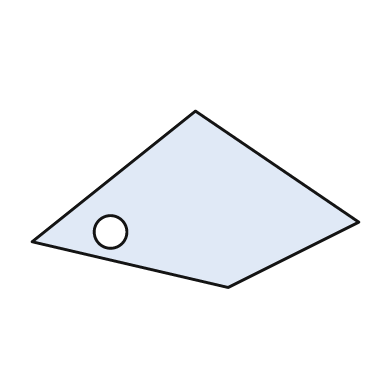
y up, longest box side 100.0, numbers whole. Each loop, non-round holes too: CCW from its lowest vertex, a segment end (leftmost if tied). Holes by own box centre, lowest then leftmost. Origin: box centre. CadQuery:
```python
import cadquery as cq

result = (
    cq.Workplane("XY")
    .moveTo(10.0, -27.0)
    .lineTo(50.0, -7.0)
    .lineTo(0.0, 27.0)
    .lineTo(-50.0, -13.0)
    .close()
    .moveTo(-26.0, -10.0)
    .circle(5.0)
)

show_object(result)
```